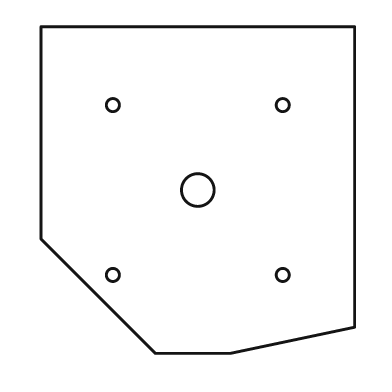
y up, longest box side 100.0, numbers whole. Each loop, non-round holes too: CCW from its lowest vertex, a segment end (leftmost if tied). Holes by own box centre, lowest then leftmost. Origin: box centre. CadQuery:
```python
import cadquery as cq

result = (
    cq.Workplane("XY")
    .moveTo(-13.0, -50.0)
    .lineTo(10.0, -50.0)
    .lineTo(48.0, -42.0)
    .lineTo(48.0, 50.0)
    .lineTo(-48.0, 50.0)
    .lineTo(-48.0, -15.0)
    .close()
    .moveTo(-26.0, -26.0)
    .circle(2.0)
    .moveTo(26.0, -26.0)
    .circle(2.0)
    .moveTo(0.0, 0.0)
    .circle(5.0)
    .moveTo(-26.0, 26.0)
    .circle(2.0)
    .moveTo(26.0, 26.0)
    .circle(2.0)
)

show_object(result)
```